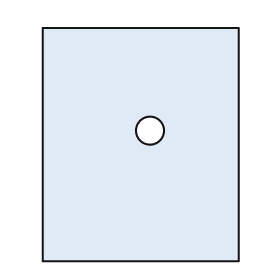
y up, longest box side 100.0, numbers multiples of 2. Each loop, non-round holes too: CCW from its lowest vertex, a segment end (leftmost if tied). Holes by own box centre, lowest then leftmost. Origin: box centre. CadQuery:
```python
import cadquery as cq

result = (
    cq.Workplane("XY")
    .moveTo(-42.0, -50.0)
    .lineTo(42.0, -50.0)
    .lineTo(42.0, 50.0)
    .lineTo(-42.0, 50.0)
    .close()
    .moveTo(4.0, 6.0)
    .circle(6.0)
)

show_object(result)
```